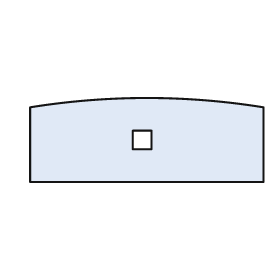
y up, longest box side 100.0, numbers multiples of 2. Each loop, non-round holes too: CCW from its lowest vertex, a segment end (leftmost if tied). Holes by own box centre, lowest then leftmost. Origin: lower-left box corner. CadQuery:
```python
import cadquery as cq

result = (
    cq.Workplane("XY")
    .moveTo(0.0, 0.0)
    .lineTo(100.0, 0.0)
    .lineTo(100.0, 32.0)
    .threePointArc((50.0, 36.0), (0.0, 32.0))
    .close()
    .moveTo(44.0, 14.0)
    .lineTo(52.0, 14.0)
    .lineTo(52.0, 22.0)
    .lineTo(44.0, 22.0)
    .close()
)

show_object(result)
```